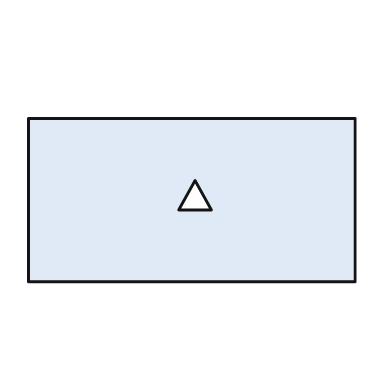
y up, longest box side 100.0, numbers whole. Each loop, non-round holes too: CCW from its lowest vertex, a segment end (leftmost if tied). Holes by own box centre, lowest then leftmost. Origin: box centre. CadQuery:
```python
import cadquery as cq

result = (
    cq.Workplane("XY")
    .moveTo(-50.0, -25.0)
    .lineTo(50.0, -25.0)
    .lineTo(50.0, 25.0)
    .lineTo(-50.0, 25.0)
    .close()
    .moveTo(-4.0, -3.0)
    .lineTo(6.0, -3.0)
    .lineTo(1.0, 6.0)
    .close()
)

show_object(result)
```